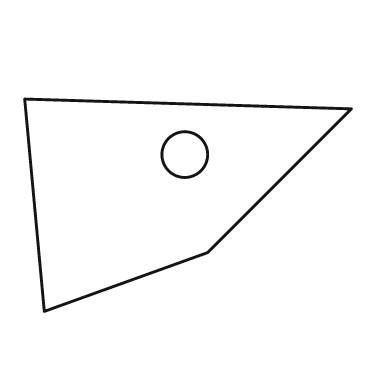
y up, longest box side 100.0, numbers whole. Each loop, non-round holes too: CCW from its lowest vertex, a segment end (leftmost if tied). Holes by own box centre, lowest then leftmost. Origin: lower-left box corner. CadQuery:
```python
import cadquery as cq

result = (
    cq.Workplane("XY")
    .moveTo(6.0, 0.0)
    .lineTo(56.0, 18.0)
    .lineTo(100.0, 62.0)
    .lineTo(0.0, 65.0)
    .close()
    .moveTo(49.0, 48.0)
    .circle(7.0)
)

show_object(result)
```